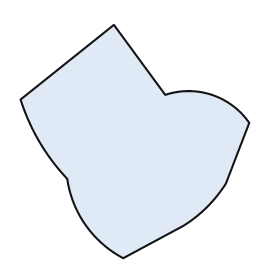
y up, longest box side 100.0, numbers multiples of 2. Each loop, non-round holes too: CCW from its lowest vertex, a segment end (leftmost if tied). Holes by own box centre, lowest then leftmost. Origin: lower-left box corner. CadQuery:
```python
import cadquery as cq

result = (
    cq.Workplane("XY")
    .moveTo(44.0, 0.0)
    .lineTo(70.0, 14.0)
    .threePointArc((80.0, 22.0), (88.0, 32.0))
    .lineTo(98.0, 58.0)
    .threePointArc((82.0, 70.0), (62.0, 70.0))
    .lineTo(40.0, 100.0)
    .lineTo(0.0, 68.0)
    .threePointArc((8.0, 50.0), (20.0, 34.0))
    .threePointArc((28.0, 14.0), (44.0, 0.0))
    .close()
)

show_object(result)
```